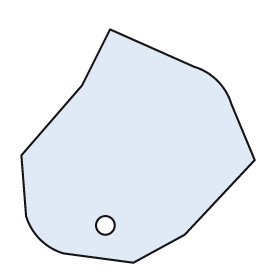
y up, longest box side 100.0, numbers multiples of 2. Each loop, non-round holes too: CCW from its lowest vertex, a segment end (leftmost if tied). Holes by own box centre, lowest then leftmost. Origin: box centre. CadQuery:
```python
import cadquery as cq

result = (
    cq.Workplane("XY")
    .moveTo(-2.0, -50.0)
    .lineTo(20.0, -38.0)
    .lineTo(50.0, -6.0)
    .lineTo(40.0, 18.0)
    .threePointArc((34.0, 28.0), (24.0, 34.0))
    .lineTo(-12.0, 50.0)
    .lineTo(-24.0, 26.0)
    .lineTo(-50.0, -4.0)
    .lineTo(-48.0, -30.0)
    .threePointArc((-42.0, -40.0), (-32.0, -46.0))
    .close()
    .moveTo(-14.0, -34.0)
    .circle(4.0)
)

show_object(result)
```